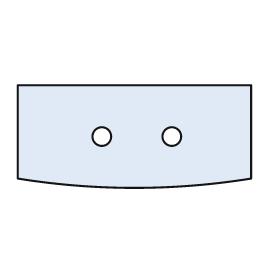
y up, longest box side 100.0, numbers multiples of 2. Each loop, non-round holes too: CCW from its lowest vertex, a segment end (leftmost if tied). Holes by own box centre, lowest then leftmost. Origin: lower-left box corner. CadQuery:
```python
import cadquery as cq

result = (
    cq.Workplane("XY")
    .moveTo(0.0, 4.0)
    .threePointArc((50.0, 0.0), (100.0, 4.0))
    .lineTo(100.0, 44.0)
    .lineTo(0.0, 44.0)
    .close()
    .moveTo(36.0, 22.0)
    .circle(4.0)
    .moveTo(66.0, 22.0)
    .circle(4.0)
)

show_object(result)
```